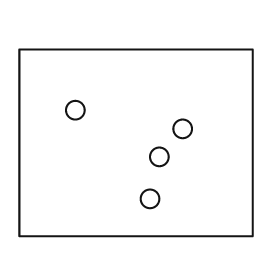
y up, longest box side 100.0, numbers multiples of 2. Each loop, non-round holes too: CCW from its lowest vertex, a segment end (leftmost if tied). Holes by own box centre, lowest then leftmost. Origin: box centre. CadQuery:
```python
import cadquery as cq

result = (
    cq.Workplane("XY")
    .moveTo(-50.0, -40.0)
    .lineTo(50.0, -40.0)
    .lineTo(50.0, 40.0)
    .lineTo(-50.0, 40.0)
    .close()
    .moveTo(6.0, -24.0)
    .circle(4.0)
    .moveTo(10.0, -6.0)
    .circle(4.0)
    .moveTo(20.0, 6.0)
    .circle(4.0)
    .moveTo(-26.0, 14.0)
    .circle(4.0)
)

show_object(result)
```